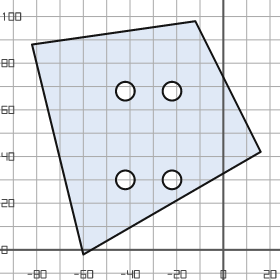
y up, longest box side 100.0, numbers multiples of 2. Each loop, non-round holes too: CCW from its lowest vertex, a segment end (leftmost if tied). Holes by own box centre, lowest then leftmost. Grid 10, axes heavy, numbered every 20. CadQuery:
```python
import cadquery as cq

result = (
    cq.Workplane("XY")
    .moveTo(-60.0, -2.0)
    .lineTo(16.0, 42.0)
    .lineTo(-12.0, 98.0)
    .lineTo(-82.0, 88.0)
    .close()
    .moveTo(-42.0, 30.0)
    .circle(4.0)
    .moveTo(-22.0, 30.0)
    .circle(4.0)
    .moveTo(-42.0, 68.0)
    .circle(4.0)
    .moveTo(-22.0, 68.0)
    .circle(4.0)
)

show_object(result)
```